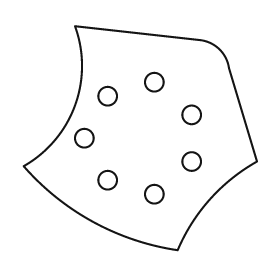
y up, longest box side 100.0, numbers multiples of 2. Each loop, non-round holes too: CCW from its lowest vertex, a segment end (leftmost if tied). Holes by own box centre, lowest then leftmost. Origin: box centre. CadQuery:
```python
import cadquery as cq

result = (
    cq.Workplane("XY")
    .moveTo(16.0, -48.0)
    .threePointArc((30.0, -26.0), (50.0, -10.0))
    .lineTo(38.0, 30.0)
    .threePointArc((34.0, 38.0), (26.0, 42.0))
    .lineTo(-28.0, 48.0)
    .threePointArc((-28.0, 14.0), (-50.0, -12.0))
    .threePointArc((-20.0, -36.0), (16.0, -48.0))
    .close()
    .moveTo(6.0, -24.0)
    .circle(4.0)
    .moveTo(-14.0, -18.0)
    .circle(4.0)
    .moveTo(22.0, -10.0)
    .circle(4.0)
    .moveTo(-24.0, 0.0)
    .circle(4.0)
    .moveTo(22.0, 10.0)
    .circle(4.0)
    .moveTo(-14.0, 18.0)
    .circle(4.0)
    .moveTo(6.0, 24.0)
    .circle(4.0)
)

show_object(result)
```